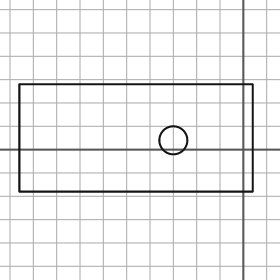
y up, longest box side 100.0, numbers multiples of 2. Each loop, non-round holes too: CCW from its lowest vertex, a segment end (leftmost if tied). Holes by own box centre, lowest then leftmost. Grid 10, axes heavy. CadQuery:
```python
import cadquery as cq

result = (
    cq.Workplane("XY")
    .moveTo(-96.0, -18.0)
    .lineTo(4.0, -18.0)
    .lineTo(4.0, 28.0)
    .lineTo(-96.0, 28.0)
    .close()
    .moveTo(-30.0, 4.0)
    .circle(6.0)
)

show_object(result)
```